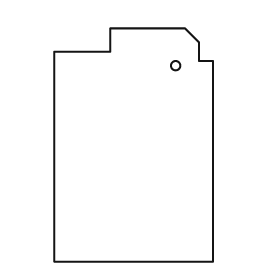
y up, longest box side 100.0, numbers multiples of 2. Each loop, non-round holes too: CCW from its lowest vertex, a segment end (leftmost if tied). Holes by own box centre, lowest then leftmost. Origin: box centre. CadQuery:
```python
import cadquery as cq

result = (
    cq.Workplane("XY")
    .moveTo(-34.0, -50.0)
    .lineTo(34.0, -50.0)
    .lineTo(34.0, 36.0)
    .lineTo(28.0, 36.0)
    .lineTo(28.0, 44.0)
    .lineTo(22.0, 50.0)
    .lineTo(-10.0, 50.0)
    .lineTo(-10.0, 40.0)
    .lineTo(-34.0, 40.0)
    .close()
    .moveTo(18.0, 34.0)
    .circle(2.0)
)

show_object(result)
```